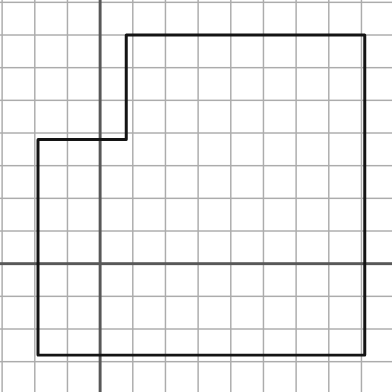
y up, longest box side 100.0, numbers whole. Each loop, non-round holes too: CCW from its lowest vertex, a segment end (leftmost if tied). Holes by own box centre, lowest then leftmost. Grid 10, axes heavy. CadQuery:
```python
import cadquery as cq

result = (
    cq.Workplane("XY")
    .moveTo(-19.0, -28.0)
    .lineTo(81.0, -28.0)
    .lineTo(81.0, 70.0)
    .lineTo(8.0, 70.0)
    .lineTo(8.0, 38.0)
    .lineTo(-19.0, 38.0)
    .close()
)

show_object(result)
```